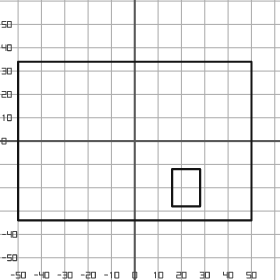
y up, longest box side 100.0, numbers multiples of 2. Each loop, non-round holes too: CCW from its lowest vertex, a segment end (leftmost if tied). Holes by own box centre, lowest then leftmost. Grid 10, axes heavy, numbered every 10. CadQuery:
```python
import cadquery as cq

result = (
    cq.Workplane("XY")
    .moveTo(-50.0, -34.0)
    .lineTo(50.0, -34.0)
    .lineTo(50.0, 34.0)
    .lineTo(-50.0, 34.0)
    .close()
    .moveTo(16.0, -28.0)
    .lineTo(28.0, -28.0)
    .lineTo(28.0, -12.0)
    .lineTo(16.0, -12.0)
    .close()
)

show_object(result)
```